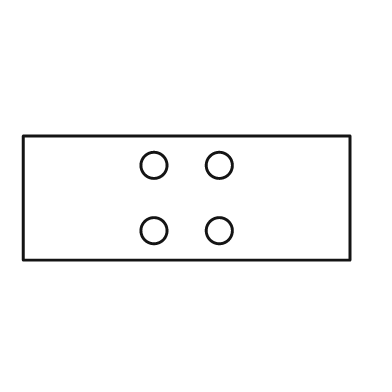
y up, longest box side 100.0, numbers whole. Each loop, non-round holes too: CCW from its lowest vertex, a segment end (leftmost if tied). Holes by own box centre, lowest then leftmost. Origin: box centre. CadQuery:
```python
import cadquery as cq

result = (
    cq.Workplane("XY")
    .moveTo(-50.0, -19.0)
    .lineTo(50.0, -19.0)
    .lineTo(50.0, 19.0)
    .lineTo(-50.0, 19.0)
    .close()
    .moveTo(-10.0, -10.0)
    .circle(4.0)
    .moveTo(10.0, -10.0)
    .circle(4.0)
    .moveTo(-10.0, 10.0)
    .circle(4.0)
    .moveTo(10.0, 10.0)
    .circle(4.0)
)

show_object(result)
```